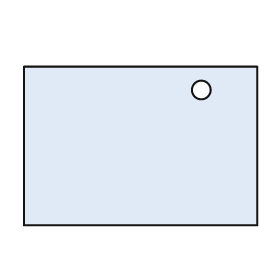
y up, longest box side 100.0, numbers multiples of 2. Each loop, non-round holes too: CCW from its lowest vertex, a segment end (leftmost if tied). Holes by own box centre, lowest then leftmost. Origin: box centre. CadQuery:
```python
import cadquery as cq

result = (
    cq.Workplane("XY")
    .moveTo(-50.0, -34.0)
    .lineTo(50.0, -34.0)
    .lineTo(50.0, 34.0)
    .lineTo(-50.0, 34.0)
    .close()
    .moveTo(26.0, 24.0)
    .circle(4.0)
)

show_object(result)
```